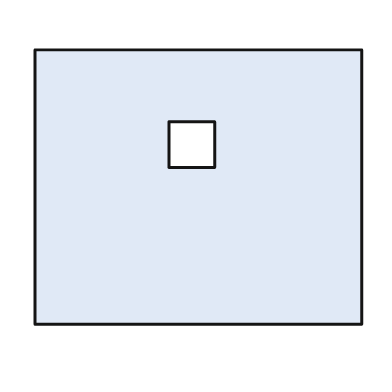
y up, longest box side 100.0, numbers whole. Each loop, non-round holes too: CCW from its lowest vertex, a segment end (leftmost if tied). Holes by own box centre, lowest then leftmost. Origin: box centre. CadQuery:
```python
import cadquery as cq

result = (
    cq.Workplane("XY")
    .moveTo(-50.0, -42.0)
    .lineTo(50.0, -42.0)
    .lineTo(50.0, 42.0)
    .lineTo(-50.0, 42.0)
    .close()
    .moveTo(-9.0, 6.0)
    .lineTo(5.0, 6.0)
    .lineTo(5.0, 20.0)
    .lineTo(-9.0, 20.0)
    .close()
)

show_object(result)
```